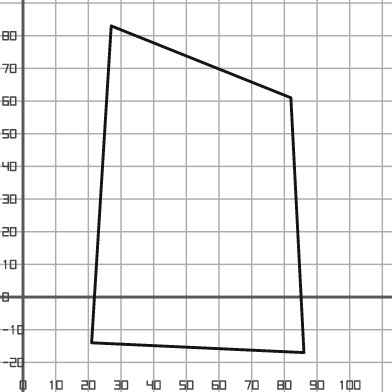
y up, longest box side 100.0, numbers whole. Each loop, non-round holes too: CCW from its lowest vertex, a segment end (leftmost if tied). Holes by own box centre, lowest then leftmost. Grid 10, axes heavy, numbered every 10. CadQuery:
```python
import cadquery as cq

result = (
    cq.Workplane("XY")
    .moveTo(86.0, -17.0)
    .lineTo(82.0, 61.0)
    .lineTo(27.0, 83.0)
    .lineTo(21.0, -14.0)
    .close()
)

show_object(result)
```